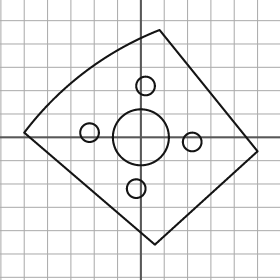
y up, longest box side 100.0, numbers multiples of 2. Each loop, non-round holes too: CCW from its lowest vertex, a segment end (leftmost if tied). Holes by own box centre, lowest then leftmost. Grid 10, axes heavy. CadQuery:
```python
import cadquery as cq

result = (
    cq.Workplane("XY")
    .moveTo(6.0, -46.0)
    .lineTo(50.0, -6.0)
    .lineTo(8.0, 46.0)
    .threePointArc((-24.0, 28.0), (-50.0, 2.0))
    .close()
    .moveTo(-2.0, -22.0)
    .circle(4.0)
    .moveTo(22.0, -2.0)
    .circle(4.0)
    .moveTo(0.0, 0.0)
    .circle(12.0)
    .moveTo(-22.0, 2.0)
    .circle(4.0)
    .moveTo(2.0, 22.0)
    .circle(4.0)
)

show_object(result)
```